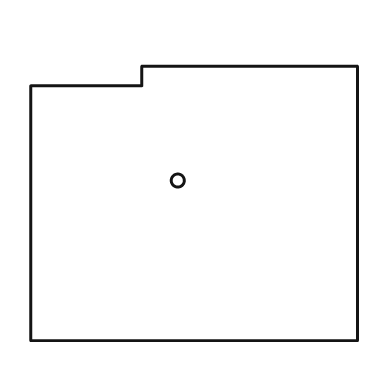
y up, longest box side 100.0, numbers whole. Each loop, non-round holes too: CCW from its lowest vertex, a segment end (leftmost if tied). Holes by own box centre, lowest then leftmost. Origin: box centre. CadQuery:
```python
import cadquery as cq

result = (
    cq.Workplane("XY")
    .moveTo(-50.0, -42.0)
    .lineTo(50.0, -42.0)
    .lineTo(50.0, 42.0)
    .lineTo(-16.0, 42.0)
    .lineTo(-16.0, 36.0)
    .lineTo(-50.0, 36.0)
    .close()
    .moveTo(-5.0, 7.0)
    .circle(2.0)
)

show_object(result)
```